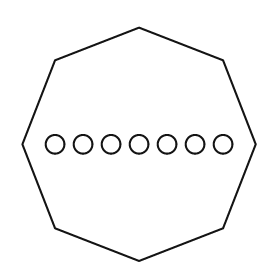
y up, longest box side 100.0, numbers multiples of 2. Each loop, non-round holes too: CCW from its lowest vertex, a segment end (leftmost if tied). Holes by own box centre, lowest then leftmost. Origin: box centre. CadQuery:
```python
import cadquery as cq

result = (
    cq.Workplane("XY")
    .moveTo(0.0, -50.0)
    .lineTo(36.0, -36.0)
    .lineTo(50.0, 0.0)
    .lineTo(36.0, 36.0)
    .lineTo(0.0, 50.0)
    .lineTo(-36.0, 36.0)
    .lineTo(-50.0, 0.0)
    .lineTo(-36.0, -36.0)
    .close()
    .moveTo(-36.0, 0.0)
    .circle(4.0)
    .moveTo(-24.0, 0.0)
    .circle(4.0)
    .moveTo(-12.0, 0.0)
    .circle(4.0)
    .moveTo(0.0, 0.0)
    .circle(4.0)
    .moveTo(12.0, 0.0)
    .circle(4.0)
    .moveTo(24.0, 0.0)
    .circle(4.0)
    .moveTo(36.0, 0.0)
    .circle(4.0)
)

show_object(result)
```